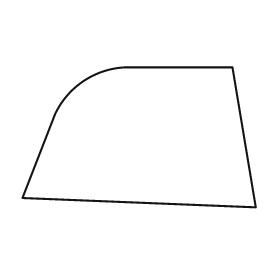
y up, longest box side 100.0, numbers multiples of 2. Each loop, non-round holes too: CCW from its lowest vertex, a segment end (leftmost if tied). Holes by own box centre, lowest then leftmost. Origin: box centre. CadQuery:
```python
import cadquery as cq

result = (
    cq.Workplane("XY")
    .moveTo(50.0, -30.0)
    .lineTo(40.0, 30.0)
    .lineTo(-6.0, 30.0)
    .threePointArc((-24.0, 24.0), (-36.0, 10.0))
    .lineTo(-50.0, -26.0)
    .close()
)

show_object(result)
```